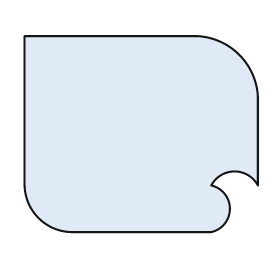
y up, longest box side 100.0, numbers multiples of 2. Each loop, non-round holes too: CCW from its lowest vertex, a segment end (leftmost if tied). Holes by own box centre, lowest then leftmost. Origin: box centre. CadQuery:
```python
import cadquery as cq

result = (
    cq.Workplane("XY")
    .moveTo(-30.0, -42.0)
    .lineTo(30.0, -42.0)
    .threePointArc((38.0, -32.0), (30.0, -22.0))
    .threePointArc((40.0, -16.0), (50.0, -22.0))
    .lineTo(50.0, 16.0)
    .threePointArc((42.0, 34.0), (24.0, 42.0))
    .lineTo(-50.0, 42.0)
    .lineTo(-50.0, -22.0)
    .threePointArc((-44.0, -36.0), (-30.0, -42.0))
    .close()
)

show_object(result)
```